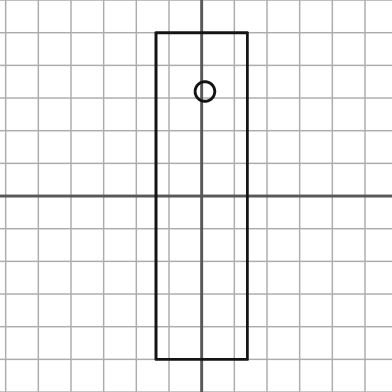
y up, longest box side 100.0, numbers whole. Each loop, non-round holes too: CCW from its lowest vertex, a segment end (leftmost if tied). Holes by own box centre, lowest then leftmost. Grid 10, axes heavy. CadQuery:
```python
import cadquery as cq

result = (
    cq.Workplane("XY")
    .moveTo(-14.0, -50.0)
    .lineTo(14.0, -50.0)
    .lineTo(14.0, 50.0)
    .lineTo(-14.0, 50.0)
    .close()
    .moveTo(1.0, 32.0)
    .circle(3.0)
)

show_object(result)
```